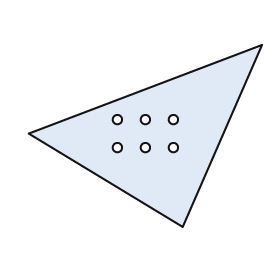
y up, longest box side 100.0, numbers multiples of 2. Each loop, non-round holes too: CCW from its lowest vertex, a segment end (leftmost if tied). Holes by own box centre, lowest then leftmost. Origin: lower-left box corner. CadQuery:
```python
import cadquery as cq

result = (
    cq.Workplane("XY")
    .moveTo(66.0, 0.0)
    .lineTo(100.0, 78.0)
    .lineTo(0.0, 40.0)
    .close()
    .moveTo(38.0, 34.0)
    .circle(2.0)
    .moveTo(50.0, 34.0)
    .circle(2.0)
    .moveTo(62.0, 34.0)
    .circle(2.0)
    .moveTo(38.0, 46.0)
    .circle(2.0)
    .moveTo(50.0, 46.0)
    .circle(2.0)
    .moveTo(62.0, 46.0)
    .circle(2.0)
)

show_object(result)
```